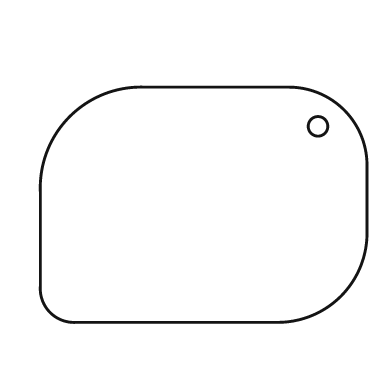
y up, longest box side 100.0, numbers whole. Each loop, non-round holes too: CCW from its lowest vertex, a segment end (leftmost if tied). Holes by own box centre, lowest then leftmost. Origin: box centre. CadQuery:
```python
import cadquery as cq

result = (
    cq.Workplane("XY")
    .moveTo(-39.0, -36.0)
    .lineTo(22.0, -36.0)
    .threePointArc((42.0, -28.0), (50.0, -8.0))
    .lineTo(50.0, 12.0)
    .threePointArc((43.0, 29.0), (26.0, 36.0))
    .lineTo(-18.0, 36.0)
    .threePointArc((-41.0, 27.0), (-50.0, 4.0))
    .lineTo(-50.0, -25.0)
    .threePointArc((-47.0, -33.0), (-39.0, -36.0))
    .close()
    .moveTo(35.0, 24.0)
    .circle(3.0)
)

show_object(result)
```